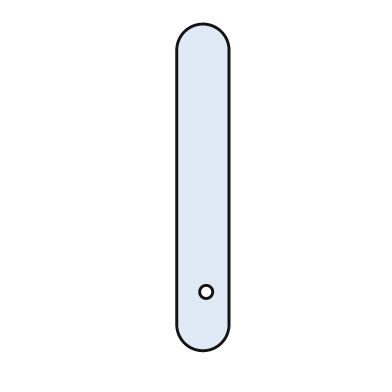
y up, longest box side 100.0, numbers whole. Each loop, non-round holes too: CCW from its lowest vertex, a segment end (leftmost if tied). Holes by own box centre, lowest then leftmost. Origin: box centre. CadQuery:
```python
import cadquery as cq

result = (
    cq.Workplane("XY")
    .moveTo(-8.0, -42.0)
    .threePointArc((0.0, -50.0), (8.0, -42.0))
    .lineTo(8.0, 42.0)
    .threePointArc((0.0, 50.0), (-8.0, 42.0))
    .close()
    .moveTo(1.0, -32.0)
    .circle(2.0)
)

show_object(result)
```